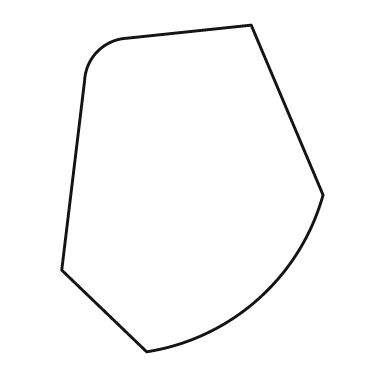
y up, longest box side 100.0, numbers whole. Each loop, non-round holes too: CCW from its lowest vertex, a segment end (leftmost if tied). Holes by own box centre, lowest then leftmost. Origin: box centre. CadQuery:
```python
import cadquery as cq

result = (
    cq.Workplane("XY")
    .moveTo(-14.0, -50.0)
    .threePointArc((20.0, -34.0), (40.0, -2.0))
    .lineTo(18.0, 50.0)
    .lineTo(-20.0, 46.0)
    .threePointArc((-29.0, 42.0), (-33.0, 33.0))
    .lineTo(-40.0, -25.0)
    .close()
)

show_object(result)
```